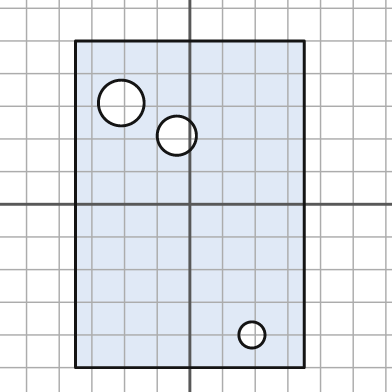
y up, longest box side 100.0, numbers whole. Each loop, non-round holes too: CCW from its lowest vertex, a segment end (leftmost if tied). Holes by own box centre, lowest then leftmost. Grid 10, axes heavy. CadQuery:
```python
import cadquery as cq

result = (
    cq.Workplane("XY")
    .moveTo(-35.0, -50.0)
    .lineTo(35.0, -50.0)
    .lineTo(35.0, 50.0)
    .lineTo(-35.0, 50.0)
    .close()
    .moveTo(19.0, -40.0)
    .circle(4.0)
    .moveTo(-4.0, 21.0)
    .circle(6.0)
    .moveTo(-21.0, 31.0)
    .circle(7.0)
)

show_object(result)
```